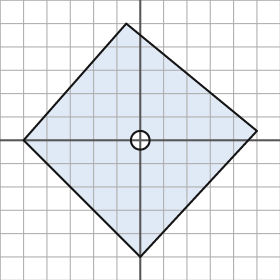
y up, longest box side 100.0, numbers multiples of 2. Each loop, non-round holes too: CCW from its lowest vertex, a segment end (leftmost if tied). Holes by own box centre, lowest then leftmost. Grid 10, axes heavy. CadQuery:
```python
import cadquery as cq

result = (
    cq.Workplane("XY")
    .moveTo(0.0, -50.0)
    .lineTo(50.0, 4.0)
    .lineTo(-6.0, 50.0)
    .lineTo(-50.0, 0.0)
    .close()
    .moveTo(0.0, 0.0)
    .circle(4.0)
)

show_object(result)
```